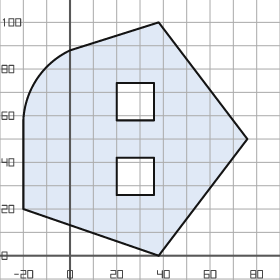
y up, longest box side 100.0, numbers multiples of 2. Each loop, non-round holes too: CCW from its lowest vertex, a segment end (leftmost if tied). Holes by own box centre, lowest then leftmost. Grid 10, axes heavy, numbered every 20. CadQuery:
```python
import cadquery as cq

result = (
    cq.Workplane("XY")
    .moveTo(38.0, 0.0)
    .lineTo(76.0, 50.0)
    .lineTo(38.0, 100.0)
    .lineTo(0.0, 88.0)
    .threePointArc((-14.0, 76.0), (-20.0, 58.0))
    .lineTo(-20.0, 20.0)
    .close()
    .moveTo(20.0, 26.0)
    .lineTo(36.0, 26.0)
    .lineTo(36.0, 42.0)
    .lineTo(20.0, 42.0)
    .close()
    .moveTo(20.0, 58.0)
    .lineTo(36.0, 58.0)
    .lineTo(36.0, 74.0)
    .lineTo(20.0, 74.0)
    .close()
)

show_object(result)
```